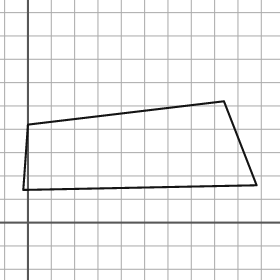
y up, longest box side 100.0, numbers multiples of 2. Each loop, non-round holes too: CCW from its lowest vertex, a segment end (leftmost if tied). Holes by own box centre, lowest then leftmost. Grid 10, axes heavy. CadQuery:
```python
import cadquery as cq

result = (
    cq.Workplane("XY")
    .moveTo(-2.0, 14.0)
    .lineTo(98.0, 16.0)
    .lineTo(84.0, 52.0)
    .lineTo(0.0, 42.0)
    .close()
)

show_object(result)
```